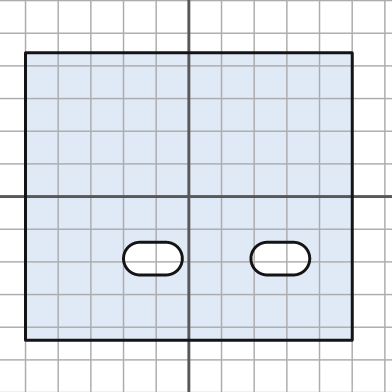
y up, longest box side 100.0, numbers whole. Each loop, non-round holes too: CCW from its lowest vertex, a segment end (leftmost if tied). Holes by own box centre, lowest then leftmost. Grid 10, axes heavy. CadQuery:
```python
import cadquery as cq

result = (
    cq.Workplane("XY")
    .moveTo(-50.0, -44.0)
    .lineTo(50.0, -44.0)
    .lineTo(50.0, 44.0)
    .lineTo(-50.0, 44.0)
    .close()
    .moveTo(-15.0, -24.0)
    .lineTo(-7.0, -24.0)
    .threePointArc((-2.0, -19.0), (-7.0, -14.0))
    .lineTo(-15.0, -14.0)
    .threePointArc((-20.0, -19.0), (-15.0, -24.0))
    .close()
    .moveTo(24.0, -24.0)
    .lineTo(32.0, -24.0)
    .threePointArc((37.0, -19.0), (32.0, -14.0))
    .lineTo(24.0, -14.0)
    .threePointArc((19.0, -19.0), (24.0, -24.0))
    .close()
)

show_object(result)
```